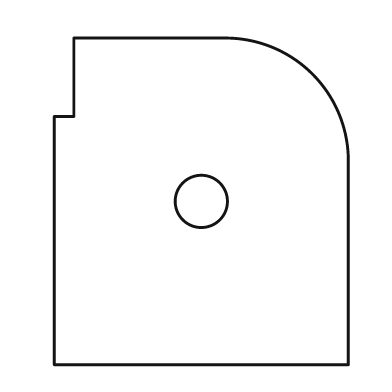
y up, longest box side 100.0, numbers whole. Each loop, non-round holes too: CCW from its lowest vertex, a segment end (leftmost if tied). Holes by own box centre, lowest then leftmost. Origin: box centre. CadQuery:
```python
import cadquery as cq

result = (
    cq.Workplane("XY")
    .moveTo(-45.0, -50.0)
    .lineTo(45.0, -50.0)
    .lineTo(45.0, 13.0)
    .threePointArc((34.0, 39.0), (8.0, 50.0))
    .lineTo(-39.0, 50.0)
    .lineTo(-39.0, 26.0)
    .lineTo(-45.0, 26.0)
    .close()
    .moveTo(0.0, 0.0)
    .circle(8.0)
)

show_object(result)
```